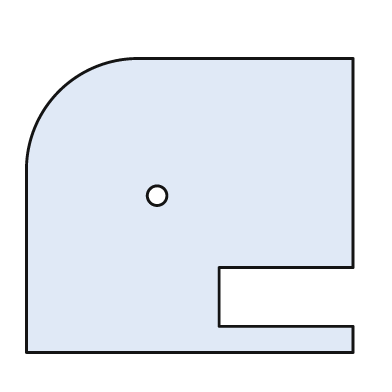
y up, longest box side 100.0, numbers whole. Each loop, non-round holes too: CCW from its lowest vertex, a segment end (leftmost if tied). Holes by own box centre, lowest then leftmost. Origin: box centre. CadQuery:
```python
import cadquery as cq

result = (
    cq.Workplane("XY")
    .moveTo(-50.0, -45.0)
    .lineTo(50.0, -45.0)
    .lineTo(50.0, -37.0)
    .lineTo(9.0, -37.0)
    .lineTo(9.0, -19.0)
    .lineTo(50.0, -19.0)
    .lineTo(50.0, 45.0)
    .lineTo(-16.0, 45.0)
    .threePointArc((-40.0, 35.0), (-50.0, 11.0))
    .close()
    .moveTo(-10.0, 3.0)
    .circle(3.0)
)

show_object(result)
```